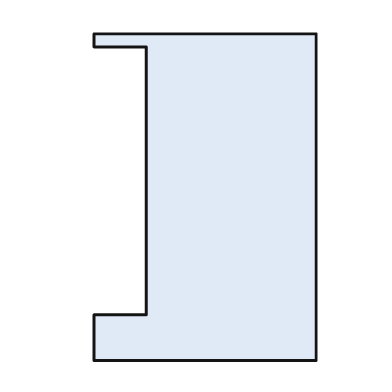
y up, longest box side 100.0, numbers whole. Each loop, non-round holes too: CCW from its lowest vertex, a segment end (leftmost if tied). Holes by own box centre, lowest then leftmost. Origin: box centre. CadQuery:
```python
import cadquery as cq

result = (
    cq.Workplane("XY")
    .moveTo(-34.0, -50.0)
    .lineTo(34.0, -50.0)
    .lineTo(34.0, 50.0)
    .lineTo(-34.0, 50.0)
    .lineTo(-34.0, 46.0)
    .lineTo(-18.0, 46.0)
    .lineTo(-18.0, -36.0)
    .lineTo(-34.0, -36.0)
    .close()
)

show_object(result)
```